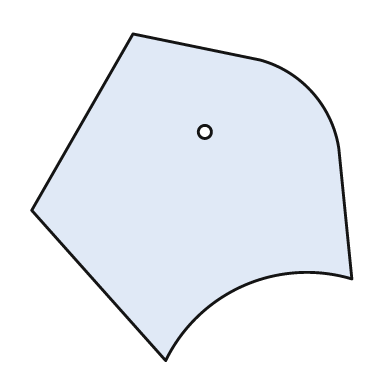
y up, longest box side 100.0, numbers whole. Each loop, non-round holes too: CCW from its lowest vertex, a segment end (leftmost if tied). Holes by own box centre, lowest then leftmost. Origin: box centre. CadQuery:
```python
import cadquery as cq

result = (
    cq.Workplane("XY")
    .moveTo(-8.0, -50.0)
    .threePointArc((16.0, -27.0), (49.0, -25.0))
    .lineTo(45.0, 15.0)
    .threePointArc((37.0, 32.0), (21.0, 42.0))
    .lineTo(-18.0, 50.0)
    .lineTo(-49.0, -4.0)
    .close()
    .moveTo(4.0, 20.0)
    .circle(2.0)
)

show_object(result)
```